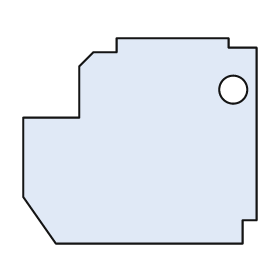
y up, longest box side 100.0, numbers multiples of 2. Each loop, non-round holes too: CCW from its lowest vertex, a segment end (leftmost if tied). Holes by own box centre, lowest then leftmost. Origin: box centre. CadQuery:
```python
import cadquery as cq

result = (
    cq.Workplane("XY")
    .moveTo(-36.0, -44.0)
    .lineTo(44.0, -44.0)
    .lineTo(44.0, -34.0)
    .lineTo(50.0, -34.0)
    .lineTo(50.0, 40.0)
    .lineTo(38.0, 40.0)
    .lineTo(38.0, 44.0)
    .lineTo(-10.0, 44.0)
    .lineTo(-10.0, 38.0)
    .lineTo(-20.0, 38.0)
    .lineTo(-26.0, 32.0)
    .lineTo(-26.0, 10.0)
    .lineTo(-50.0, 10.0)
    .lineTo(-50.0, -24.0)
    .close()
    .moveTo(40.0, 22.0)
    .circle(6.0)
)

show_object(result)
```